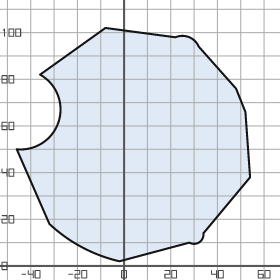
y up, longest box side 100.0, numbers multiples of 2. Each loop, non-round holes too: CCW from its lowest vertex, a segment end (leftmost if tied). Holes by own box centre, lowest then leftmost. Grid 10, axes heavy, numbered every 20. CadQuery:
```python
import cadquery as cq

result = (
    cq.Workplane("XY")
    .moveTo(-2.0, 2.0)
    .lineTo(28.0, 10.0)
    .threePointArc((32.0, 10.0), (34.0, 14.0))
    .lineTo(54.0, 38.0)
    .lineTo(52.0, 66.0)
    .lineTo(48.0, 76.0)
    .lineTo(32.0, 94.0)
    .threePointArc((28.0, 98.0), (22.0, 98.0))
    .lineTo(-8.0, 102.0)
    .lineTo(-36.0, 82.0)
    .threePointArc((-28.0, 62.0), (-46.0, 50.0))
    .lineTo(-32.0, 18.0)
    .threePointArc((-18.0, 8.0), (-2.0, 2.0))
    .close()
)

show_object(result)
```